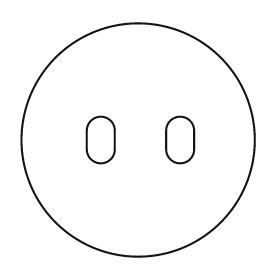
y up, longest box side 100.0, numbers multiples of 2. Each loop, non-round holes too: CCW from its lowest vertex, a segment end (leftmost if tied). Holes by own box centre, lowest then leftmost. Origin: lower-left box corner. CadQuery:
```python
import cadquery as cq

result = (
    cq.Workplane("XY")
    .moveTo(50.0, 50.0)
    .circle(50.0)
    .moveTo(28.0, 46.0)
    .threePointArc((34.0, 40.0), (40.0, 46.0))
    .lineTo(40.0, 54.0)
    .threePointArc((34.0, 60.0), (28.0, 54.0))
    .close()
    .moveTo(62.0, 46.0)
    .threePointArc((68.0, 40.0), (74.0, 46.0))
    .lineTo(74.0, 54.0)
    .threePointArc((68.0, 60.0), (62.0, 54.0))
    .close()
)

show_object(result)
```